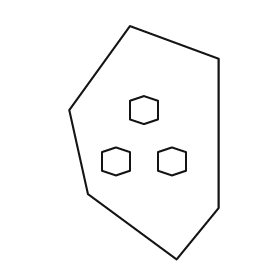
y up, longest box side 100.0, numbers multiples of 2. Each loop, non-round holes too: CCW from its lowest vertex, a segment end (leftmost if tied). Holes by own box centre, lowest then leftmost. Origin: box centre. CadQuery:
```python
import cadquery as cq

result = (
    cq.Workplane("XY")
    .moveTo(14.0, -50.0)
    .lineTo(32.0, -28.0)
    .lineTo(32.0, 36.0)
    .lineTo(-6.0, 50.0)
    .lineTo(-32.0, 14.0)
    .lineTo(-24.0, -22.0)
    .close()
    .moveTo(-12.0, -14.0)
    .lineTo(-6.0, -12.0)
    .lineTo(-6.0, -4.0)
    .lineTo(-12.0, -2.0)
    .lineTo(-18.0, -4.0)
    .lineTo(-18.0, -12.0)
    .close()
    .moveTo(12.0, -14.0)
    .lineTo(18.0, -12.0)
    .lineTo(18.0, -4.0)
    .lineTo(12.0, -2.0)
    .lineTo(6.0, -4.0)
    .lineTo(6.0, -12.0)
    .close()
    .moveTo(0.0, 8.0)
    .lineTo(6.0, 10.0)
    .lineTo(6.0, 18.0)
    .lineTo(0.0, 20.0)
    .lineTo(-6.0, 18.0)
    .lineTo(-6.0, 10.0)
    .close()
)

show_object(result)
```